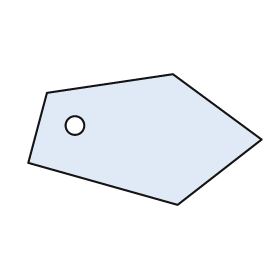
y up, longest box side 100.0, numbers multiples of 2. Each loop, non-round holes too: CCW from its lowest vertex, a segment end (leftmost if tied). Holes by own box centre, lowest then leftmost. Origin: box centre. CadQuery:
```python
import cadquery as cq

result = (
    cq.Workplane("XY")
    .moveTo(14.0, -28.0)
    .lineTo(50.0, 0.0)
    .lineTo(12.0, 28.0)
    .lineTo(-42.0, 20.0)
    .lineTo(-50.0, -10.0)
    .close()
    .moveTo(-30.0, 6.0)
    .circle(4.0)
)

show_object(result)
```